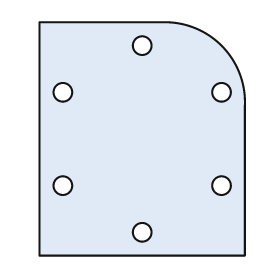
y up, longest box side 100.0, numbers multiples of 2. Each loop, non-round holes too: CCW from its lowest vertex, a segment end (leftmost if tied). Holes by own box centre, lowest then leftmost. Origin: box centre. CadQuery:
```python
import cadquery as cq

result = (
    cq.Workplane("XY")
    .moveTo(-44.0, -50.0)
    .lineTo(44.0, -50.0)
    .lineTo(44.0, 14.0)
    .threePointArc((34.0, 40.0), (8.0, 50.0))
    .lineTo(-44.0, 50.0)
    .close()
    .moveTo(0.0, -40.0)
    .circle(4.0)
    .moveTo(-34.0, -20.0)
    .circle(4.0)
    .moveTo(34.0, -20.0)
    .circle(4.0)
    .moveTo(-34.0, 20.0)
    .circle(4.0)
    .moveTo(34.0, 20.0)
    .circle(4.0)
    .moveTo(0.0, 40.0)
    .circle(4.0)
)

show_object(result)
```